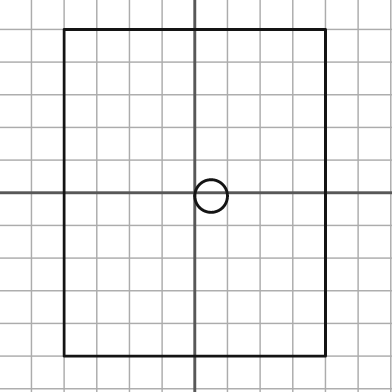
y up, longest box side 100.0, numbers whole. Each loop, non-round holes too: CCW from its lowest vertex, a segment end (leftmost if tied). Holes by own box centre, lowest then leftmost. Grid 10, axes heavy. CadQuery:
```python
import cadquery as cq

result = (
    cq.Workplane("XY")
    .moveTo(-40.0, -50.0)
    .lineTo(40.0, -50.0)
    .lineTo(40.0, 50.0)
    .lineTo(-40.0, 50.0)
    .close()
    .moveTo(5.0, -1.0)
    .circle(5.0)
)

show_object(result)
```